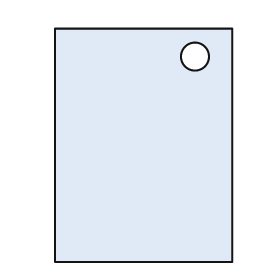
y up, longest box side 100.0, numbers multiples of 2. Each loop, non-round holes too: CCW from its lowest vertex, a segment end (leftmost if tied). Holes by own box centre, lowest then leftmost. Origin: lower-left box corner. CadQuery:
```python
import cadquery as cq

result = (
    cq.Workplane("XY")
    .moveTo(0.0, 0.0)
    .lineTo(76.0, 0.0)
    .lineTo(76.0, 100.0)
    .lineTo(0.0, 100.0)
    .close()
    .moveTo(60.0, 88.0)
    .circle(6.0)
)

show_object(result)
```